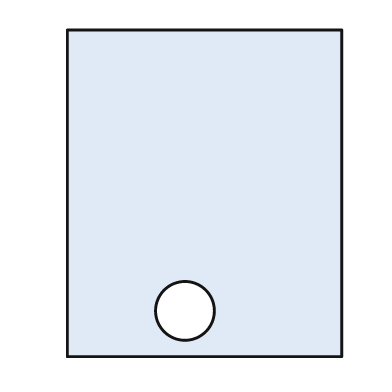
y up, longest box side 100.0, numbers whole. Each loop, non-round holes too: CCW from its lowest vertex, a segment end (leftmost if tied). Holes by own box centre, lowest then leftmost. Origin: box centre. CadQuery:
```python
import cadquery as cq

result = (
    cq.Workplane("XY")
    .moveTo(-42.0, -50.0)
    .lineTo(42.0, -50.0)
    .lineTo(42.0, 50.0)
    .lineTo(-42.0, 50.0)
    .close()
    .moveTo(-6.0, -36.0)
    .circle(9.0)
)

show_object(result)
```